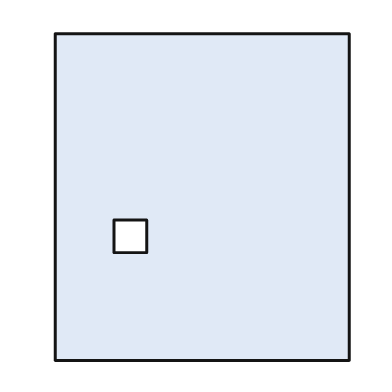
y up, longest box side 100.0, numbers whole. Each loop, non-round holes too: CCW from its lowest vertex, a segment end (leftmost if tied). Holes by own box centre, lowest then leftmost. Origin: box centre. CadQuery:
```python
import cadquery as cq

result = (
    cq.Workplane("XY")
    .moveTo(-45.0, -50.0)
    .lineTo(45.0, -50.0)
    .lineTo(45.0, 50.0)
    .lineTo(-45.0, 50.0)
    .close()
    .moveTo(-27.0, -17.0)
    .lineTo(-17.0, -17.0)
    .lineTo(-17.0, -7.0)
    .lineTo(-27.0, -7.0)
    .close()
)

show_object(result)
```